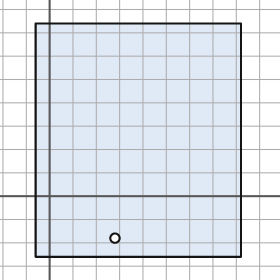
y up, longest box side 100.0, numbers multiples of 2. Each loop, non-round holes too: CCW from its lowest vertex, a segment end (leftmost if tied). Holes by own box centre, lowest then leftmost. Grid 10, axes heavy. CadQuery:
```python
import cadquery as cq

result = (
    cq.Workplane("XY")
    .moveTo(-6.0, -26.0)
    .lineTo(82.0, -26.0)
    .lineTo(82.0, 74.0)
    .lineTo(-6.0, 74.0)
    .close()
    .moveTo(28.0, -18.0)
    .circle(2.0)
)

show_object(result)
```